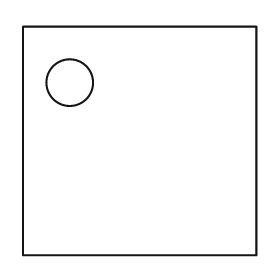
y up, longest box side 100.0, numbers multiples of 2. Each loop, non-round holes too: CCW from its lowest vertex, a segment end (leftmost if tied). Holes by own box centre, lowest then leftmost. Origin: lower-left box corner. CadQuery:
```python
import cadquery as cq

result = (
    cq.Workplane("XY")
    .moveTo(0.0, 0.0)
    .lineTo(100.0, 0.0)
    .lineTo(100.0, 98.0)
    .lineTo(0.0, 98.0)
    .close()
    .moveTo(20.0, 74.0)
    .circle(10.0)
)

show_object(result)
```